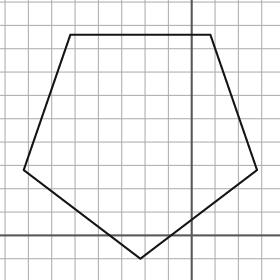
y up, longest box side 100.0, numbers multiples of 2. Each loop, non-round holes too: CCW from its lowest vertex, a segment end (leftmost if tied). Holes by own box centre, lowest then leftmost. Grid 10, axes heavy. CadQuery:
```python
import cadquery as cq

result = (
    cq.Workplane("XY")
    .moveTo(-22.0, -10.0)
    .lineTo(28.0, 28.0)
    .lineTo(8.0, 86.0)
    .lineTo(-52.0, 86.0)
    .lineTo(-72.0, 28.0)
    .close()
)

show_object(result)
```